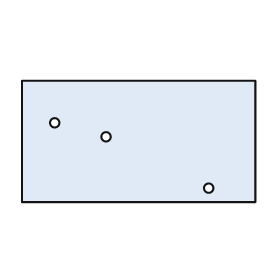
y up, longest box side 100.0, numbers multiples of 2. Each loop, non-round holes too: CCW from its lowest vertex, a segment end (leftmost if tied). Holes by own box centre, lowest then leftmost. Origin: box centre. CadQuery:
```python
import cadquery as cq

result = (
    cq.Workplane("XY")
    .moveTo(-50.0, -26.0)
    .lineTo(50.0, -26.0)
    .lineTo(50.0, 26.0)
    .lineTo(-50.0, 26.0)
    .close()
    .moveTo(30.0, -20.0)
    .circle(2.0)
    .moveTo(-14.0, 2.0)
    .circle(2.0)
    .moveTo(-36.0, 8.0)
    .circle(2.0)
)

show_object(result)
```